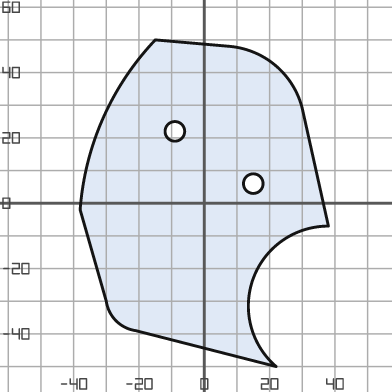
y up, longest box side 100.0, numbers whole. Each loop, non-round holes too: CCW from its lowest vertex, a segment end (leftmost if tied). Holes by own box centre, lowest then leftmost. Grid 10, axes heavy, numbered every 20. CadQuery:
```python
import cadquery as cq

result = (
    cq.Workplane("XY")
    .moveTo(22.0, -50.0)
    .threePointArc((15.0, -23.0), (38.0, -7.0))
    .lineTo(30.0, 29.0)
    .threePointArc((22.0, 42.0), (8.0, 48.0))
    .lineTo(-15.0, 50.0)
    .threePointArc((-31.0, 26.0), (-38.0, -2.0))
    .lineTo(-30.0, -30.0)
    .threePointArc((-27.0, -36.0), (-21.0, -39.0))
    .close()
    .moveTo(15.0, 6.0)
    .circle(3.0)
    .moveTo(-9.0, 22.0)
    .circle(3.0)
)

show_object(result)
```